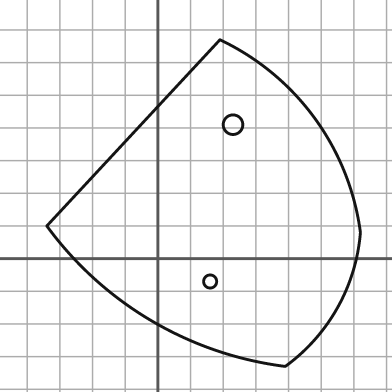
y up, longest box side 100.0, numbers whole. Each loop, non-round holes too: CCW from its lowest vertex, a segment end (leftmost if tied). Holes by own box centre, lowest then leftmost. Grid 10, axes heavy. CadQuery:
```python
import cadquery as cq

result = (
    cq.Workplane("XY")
    .moveTo(39.0, -33.0)
    .threePointArc((55.0, -15.0), (62.0, 8.0))
    .threePointArc((48.0, 43.0), (19.0, 67.0))
    .lineTo(-34.0, 10.0)
    .threePointArc((-2.0, -19.0), (39.0, -33.0))
    .close()
    .moveTo(16.0, -7.0)
    .circle(2.0)
    .moveTo(23.0, 41.0)
    .circle(3.0)
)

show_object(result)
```